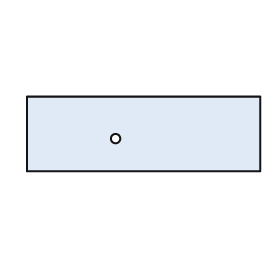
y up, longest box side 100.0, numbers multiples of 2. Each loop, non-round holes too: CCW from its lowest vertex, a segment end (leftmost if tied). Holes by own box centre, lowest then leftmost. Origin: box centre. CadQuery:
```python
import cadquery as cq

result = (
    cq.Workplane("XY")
    .moveTo(-50.0, -16.0)
    .lineTo(50.0, -16.0)
    .lineTo(50.0, 16.0)
    .lineTo(-50.0, 16.0)
    .close()
    .moveTo(-12.0, -2.0)
    .circle(2.0)
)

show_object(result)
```